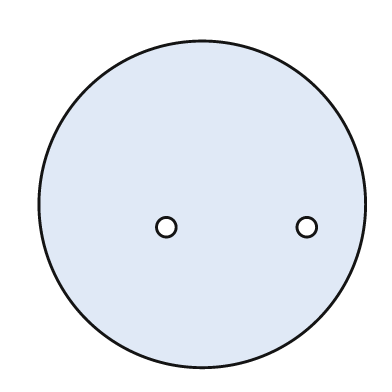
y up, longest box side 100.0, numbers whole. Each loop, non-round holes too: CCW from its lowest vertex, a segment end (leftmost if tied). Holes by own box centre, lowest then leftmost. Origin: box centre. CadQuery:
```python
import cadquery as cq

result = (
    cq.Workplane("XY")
    .moveTo(0.0, 0.0)
    .circle(50.0)
    .moveTo(-11.0, -7.0)
    .circle(3.0)
    .moveTo(32.0, -7.0)
    .circle(3.0)
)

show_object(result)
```